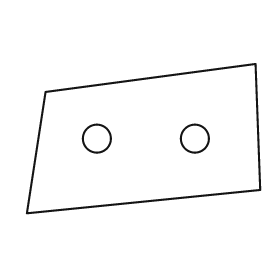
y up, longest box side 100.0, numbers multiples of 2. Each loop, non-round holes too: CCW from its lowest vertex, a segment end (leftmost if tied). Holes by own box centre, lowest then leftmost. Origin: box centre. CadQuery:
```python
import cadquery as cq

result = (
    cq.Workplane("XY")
    .moveTo(-50.0, -32.0)
    .lineTo(50.0, -22.0)
    .lineTo(48.0, 32.0)
    .lineTo(-42.0, 20.0)
    .close()
    .moveTo(-20.0, 0.0)
    .circle(6.0)
    .moveTo(22.0, 0.0)
    .circle(6.0)
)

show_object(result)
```